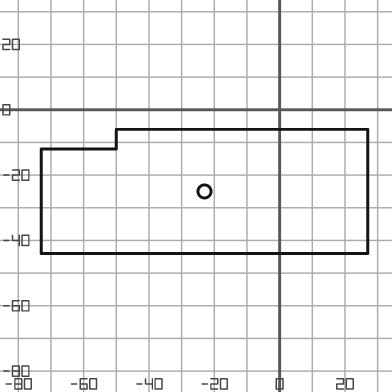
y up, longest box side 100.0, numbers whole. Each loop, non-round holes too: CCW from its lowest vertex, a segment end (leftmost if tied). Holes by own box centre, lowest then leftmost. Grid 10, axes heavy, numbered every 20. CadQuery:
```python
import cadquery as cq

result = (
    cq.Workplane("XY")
    .moveTo(-73.0, -44.0)
    .lineTo(27.0, -44.0)
    .lineTo(27.0, -6.0)
    .lineTo(-50.0, -6.0)
    .lineTo(-50.0, -12.0)
    .lineTo(-73.0, -12.0)
    .close()
    .moveTo(-23.0, -25.0)
    .circle(2.0)
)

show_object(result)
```